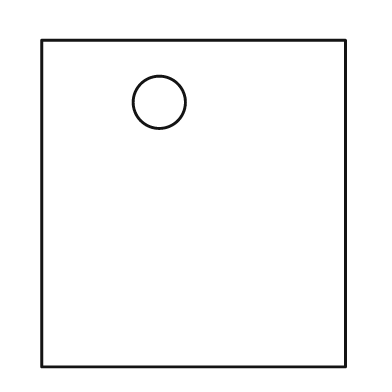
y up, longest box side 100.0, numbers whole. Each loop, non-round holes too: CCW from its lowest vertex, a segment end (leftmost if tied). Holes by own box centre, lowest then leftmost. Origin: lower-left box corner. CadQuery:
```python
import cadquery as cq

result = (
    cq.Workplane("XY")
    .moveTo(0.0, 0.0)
    .lineTo(93.0, 0.0)
    .lineTo(93.0, 100.0)
    .lineTo(0.0, 100.0)
    .close()
    .moveTo(36.0, 81.0)
    .circle(8.0)
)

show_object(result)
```